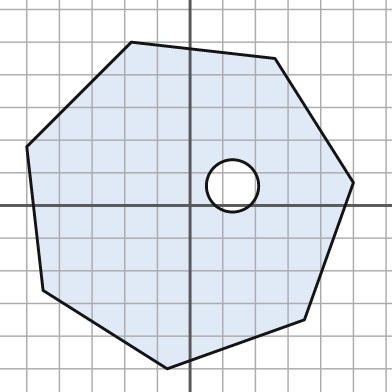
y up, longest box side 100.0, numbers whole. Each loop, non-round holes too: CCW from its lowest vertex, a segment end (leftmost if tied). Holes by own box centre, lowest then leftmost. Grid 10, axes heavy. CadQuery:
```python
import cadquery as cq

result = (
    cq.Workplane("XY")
    .moveTo(-7.0, -50.0)
    .lineTo(35.0, -35.0)
    .lineTo(50.0, 7.0)
    .lineTo(26.0, 45.0)
    .lineTo(-18.0, 50.0)
    .lineTo(-50.0, 18.0)
    .lineTo(-45.0, -26.0)
    .close()
    .moveTo(13.0, 6.0)
    .circle(8.0)
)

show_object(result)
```